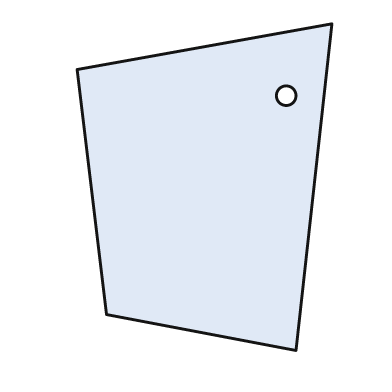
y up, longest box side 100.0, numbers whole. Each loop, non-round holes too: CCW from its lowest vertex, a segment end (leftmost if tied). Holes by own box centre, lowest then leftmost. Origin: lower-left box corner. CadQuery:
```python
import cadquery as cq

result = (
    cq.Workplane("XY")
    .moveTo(67.0, 0.0)
    .lineTo(78.0, 100.0)
    .lineTo(0.0, 86.0)
    .lineTo(9.0, 11.0)
    .close()
    .moveTo(64.0, 78.0)
    .circle(3.0)
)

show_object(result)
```